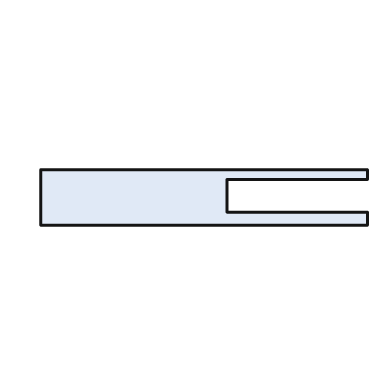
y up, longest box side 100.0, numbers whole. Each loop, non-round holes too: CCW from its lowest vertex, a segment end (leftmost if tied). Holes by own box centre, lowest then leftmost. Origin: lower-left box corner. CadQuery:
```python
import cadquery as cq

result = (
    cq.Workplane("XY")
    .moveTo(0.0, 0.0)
    .lineTo(100.0, 0.0)
    .lineTo(100.0, 4.0)
    .lineTo(57.0, 4.0)
    .lineTo(57.0, 14.0)
    .lineTo(100.0, 14.0)
    .lineTo(100.0, 17.0)
    .lineTo(0.0, 17.0)
    .close()
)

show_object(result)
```